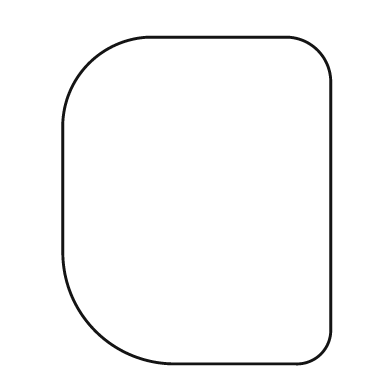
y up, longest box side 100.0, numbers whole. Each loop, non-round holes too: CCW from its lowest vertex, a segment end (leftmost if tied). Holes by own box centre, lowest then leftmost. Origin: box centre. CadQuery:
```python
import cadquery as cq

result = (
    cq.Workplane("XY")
    .moveTo(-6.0, -50.0)
    .lineTo(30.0, -50.0)
    .threePointArc((38.0, -47.0), (41.0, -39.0))
    .lineTo(41.0, 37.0)
    .threePointArc((37.0, 46.0), (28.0, 50.0))
    .lineTo(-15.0, 50.0)
    .threePointArc((-33.0, 42.0), (-41.0, 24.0))
    .lineTo(-41.0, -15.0)
    .threePointArc((-31.0, -40.0), (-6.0, -50.0))
    .close()
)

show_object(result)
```